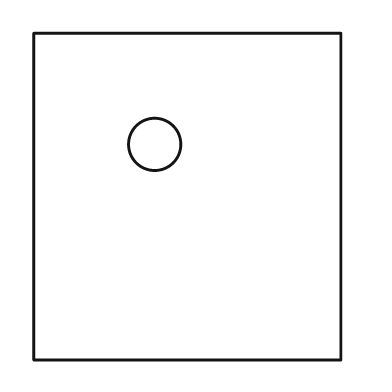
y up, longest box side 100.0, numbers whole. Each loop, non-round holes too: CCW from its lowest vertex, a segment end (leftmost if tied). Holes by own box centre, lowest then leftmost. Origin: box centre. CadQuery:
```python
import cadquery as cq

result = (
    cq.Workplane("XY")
    .moveTo(-47.0, -50.0)
    .lineTo(47.0, -50.0)
    .lineTo(47.0, 50.0)
    .lineTo(-47.0, 50.0)
    .close()
    .moveTo(-10.0, 16.0)
    .circle(8.0)
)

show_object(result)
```